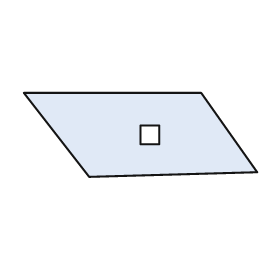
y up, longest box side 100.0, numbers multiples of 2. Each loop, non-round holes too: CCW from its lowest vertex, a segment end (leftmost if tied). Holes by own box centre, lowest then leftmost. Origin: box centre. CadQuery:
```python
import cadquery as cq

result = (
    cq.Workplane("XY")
    .moveTo(-22.0, -18.0)
    .lineTo(50.0, -16.0)
    .lineTo(26.0, 18.0)
    .lineTo(-50.0, 18.0)
    .close()
    .moveTo(0.0, -4.0)
    .lineTo(8.0, -4.0)
    .lineTo(8.0, 4.0)
    .lineTo(0.0, 4.0)
    .close()
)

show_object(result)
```